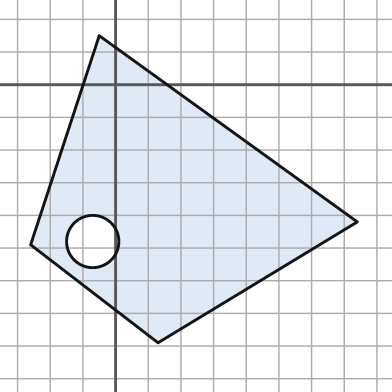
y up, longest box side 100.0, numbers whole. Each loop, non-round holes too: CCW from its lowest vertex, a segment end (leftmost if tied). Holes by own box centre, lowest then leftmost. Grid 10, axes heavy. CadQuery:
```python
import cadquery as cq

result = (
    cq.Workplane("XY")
    .moveTo(13.0, -79.0)
    .lineTo(74.0, -42.0)
    .lineTo(-5.0, 15.0)
    .lineTo(-26.0, -49.0)
    .close()
    .moveTo(-7.0, -48.0)
    .circle(8.0)
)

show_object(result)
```